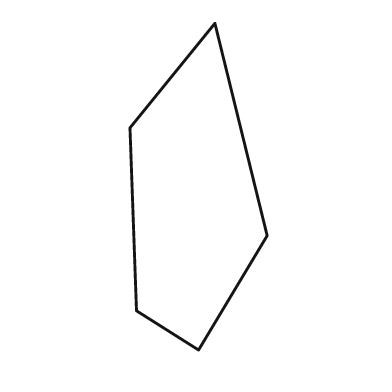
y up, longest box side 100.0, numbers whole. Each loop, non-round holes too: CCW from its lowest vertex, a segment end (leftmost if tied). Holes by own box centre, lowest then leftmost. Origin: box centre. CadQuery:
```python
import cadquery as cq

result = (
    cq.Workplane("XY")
    .moveTo(0.0, -50.0)
    .lineTo(21.0, -15.0)
    .lineTo(5.0, 50.0)
    .lineTo(-21.0, 18.0)
    .lineTo(-19.0, -38.0)
    .close()
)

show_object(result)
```